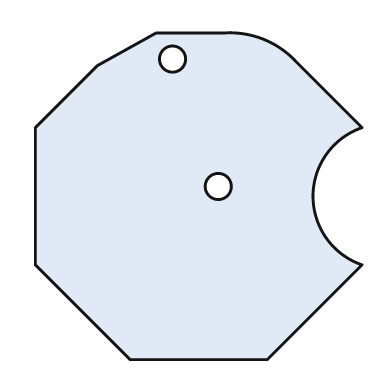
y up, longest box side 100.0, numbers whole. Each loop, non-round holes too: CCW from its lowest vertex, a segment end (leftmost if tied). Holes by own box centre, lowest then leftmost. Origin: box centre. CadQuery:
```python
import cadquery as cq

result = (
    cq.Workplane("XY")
    .moveTo(-21.0, -50.0)
    .lineTo(21.0, -50.0)
    .lineTo(50.0, -21.0)
    .threePointArc((35.0, 0.0), (50.0, 21.0))
    .lineTo(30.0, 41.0)
    .threePointArc((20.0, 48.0), (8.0, 50.0))
    .lineTo(-13.0, 50.0)
    .lineTo(-31.0, 40.0)
    .lineTo(-50.0, 21.0)
    .lineTo(-50.0, -21.0)
    .close()
    .moveTo(6.0, 3.0)
    .circle(4.0)
    .moveTo(-8.0, 42.0)
    .circle(4.0)
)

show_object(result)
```